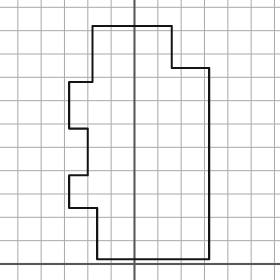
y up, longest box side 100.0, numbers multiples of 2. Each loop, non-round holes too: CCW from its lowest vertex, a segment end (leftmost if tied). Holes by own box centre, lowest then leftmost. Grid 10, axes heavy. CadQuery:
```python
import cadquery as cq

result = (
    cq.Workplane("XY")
    .moveTo(-16.0, 2.0)
    .lineTo(32.0, 2.0)
    .lineTo(32.0, 84.0)
    .lineTo(16.0, 84.0)
    .lineTo(16.0, 102.0)
    .lineTo(-18.0, 102.0)
    .lineTo(-18.0, 78.0)
    .lineTo(-28.0, 78.0)
    .lineTo(-28.0, 58.0)
    .lineTo(-20.0, 58.0)
    .lineTo(-20.0, 38.0)
    .lineTo(-28.0, 38.0)
    .lineTo(-28.0, 24.0)
    .lineTo(-16.0, 24.0)
    .close()
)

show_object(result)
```